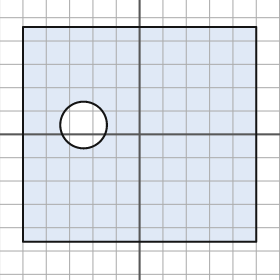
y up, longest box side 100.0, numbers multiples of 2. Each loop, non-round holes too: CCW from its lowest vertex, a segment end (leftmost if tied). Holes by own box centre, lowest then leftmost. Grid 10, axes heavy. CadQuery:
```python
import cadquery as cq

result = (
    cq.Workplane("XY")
    .moveTo(-50.0, -46.0)
    .lineTo(50.0, -46.0)
    .lineTo(50.0, 46.0)
    .lineTo(-50.0, 46.0)
    .close()
    .moveTo(-24.0, 4.0)
    .circle(10.0)
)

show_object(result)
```